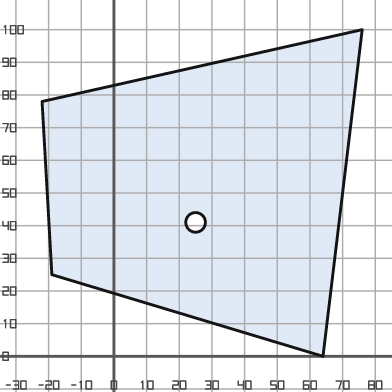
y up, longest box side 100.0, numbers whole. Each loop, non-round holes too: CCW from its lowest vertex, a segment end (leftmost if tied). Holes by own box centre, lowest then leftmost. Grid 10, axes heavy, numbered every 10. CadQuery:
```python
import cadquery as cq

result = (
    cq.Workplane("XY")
    .moveTo(64.0, 0.0)
    .lineTo(76.0, 100.0)
    .lineTo(-22.0, 78.0)
    .lineTo(-19.0, 25.0)
    .close()
    .moveTo(25.0, 41.0)
    .circle(3.0)
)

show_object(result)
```